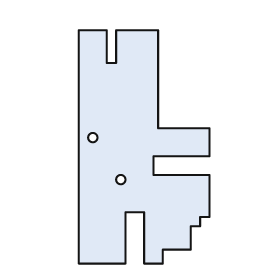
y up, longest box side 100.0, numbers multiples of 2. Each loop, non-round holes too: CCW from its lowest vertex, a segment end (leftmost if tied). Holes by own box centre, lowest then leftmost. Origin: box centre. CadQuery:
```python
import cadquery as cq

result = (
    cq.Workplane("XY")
    .moveTo(-28.0, -50.0)
    .lineTo(-8.0, -50.0)
    .lineTo(-8.0, -28.0)
    .lineTo(0.0, -28.0)
    .lineTo(0.0, -50.0)
    .lineTo(8.0, -50.0)
    .lineTo(8.0, -44.0)
    .lineTo(20.0, -44.0)
    .lineTo(20.0, -34.0)
    .lineTo(24.0, -34.0)
    .lineTo(24.0, -30.0)
    .lineTo(28.0, -30.0)
    .lineTo(28.0, -12.0)
    .lineTo(4.0, -12.0)
    .lineTo(4.0, -4.0)
    .lineTo(28.0, -4.0)
    .lineTo(28.0, 8.0)
    .lineTo(6.0, 8.0)
    .lineTo(6.0, 50.0)
    .lineTo(-12.0, 50.0)
    .lineTo(-12.0, 36.0)
    .lineTo(-16.0, 36.0)
    .lineTo(-16.0, 50.0)
    .lineTo(-28.0, 50.0)
    .close()
    .moveTo(-10.0, -14.0)
    .circle(2.0)
    .moveTo(-22.0, 4.0)
    .circle(2.0)
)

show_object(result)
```